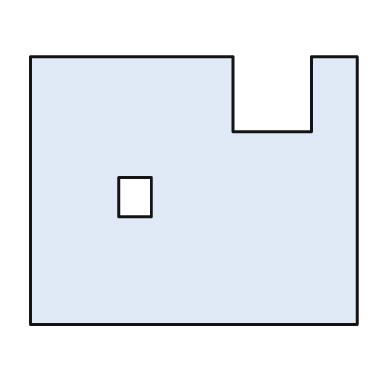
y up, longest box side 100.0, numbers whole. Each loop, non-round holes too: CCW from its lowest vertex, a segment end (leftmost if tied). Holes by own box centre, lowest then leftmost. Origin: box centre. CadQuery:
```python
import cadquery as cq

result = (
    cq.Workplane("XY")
    .moveTo(-50.0, -41.0)
    .lineTo(50.0, -41.0)
    .lineTo(50.0, 41.0)
    .lineTo(36.0, 41.0)
    .lineTo(36.0, 18.0)
    .lineTo(12.0, 18.0)
    .lineTo(12.0, 41.0)
    .lineTo(-50.0, 41.0)
    .close()
    .moveTo(-23.0, -8.0)
    .lineTo(-13.0, -8.0)
    .lineTo(-13.0, 4.0)
    .lineTo(-23.0, 4.0)
    .close()
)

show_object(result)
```